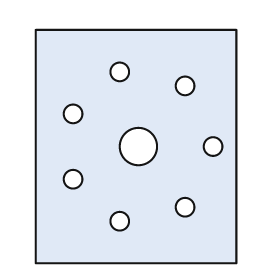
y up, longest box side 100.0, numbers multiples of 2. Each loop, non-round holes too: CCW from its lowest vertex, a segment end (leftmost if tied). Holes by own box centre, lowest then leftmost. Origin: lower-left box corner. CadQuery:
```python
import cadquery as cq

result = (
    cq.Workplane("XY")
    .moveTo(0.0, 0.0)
    .lineTo(86.0, 0.0)
    .lineTo(86.0, 100.0)
    .lineTo(0.0, 100.0)
    .close()
    .moveTo(36.0, 18.0)
    .circle(4.0)
    .moveTo(64.0, 24.0)
    .circle(4.0)
    .moveTo(16.0, 36.0)
    .circle(4.0)
    .moveTo(44.0, 50.0)
    .circle(8.0)
    .moveTo(76.0, 50.0)
    .circle(4.0)
    .moveTo(16.0, 64.0)
    .circle(4.0)
    .moveTo(64.0, 76.0)
    .circle(4.0)
    .moveTo(36.0, 82.0)
    .circle(4.0)
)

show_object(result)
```